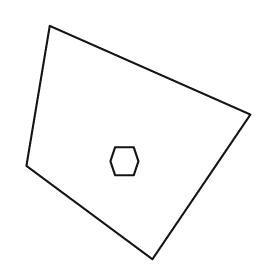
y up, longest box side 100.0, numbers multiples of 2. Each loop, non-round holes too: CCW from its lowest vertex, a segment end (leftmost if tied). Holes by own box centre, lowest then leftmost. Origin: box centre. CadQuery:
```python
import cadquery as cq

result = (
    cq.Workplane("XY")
    .moveTo(6.0, -50.0)
    .lineTo(48.0, 12.0)
    .lineTo(-38.0, 50.0)
    .lineTo(-48.0, -10.0)
    .close()
    .moveTo(-10.0, -14.0)
    .lineTo(-2.0, -14.0)
    .lineTo(0.0, -8.0)
    .lineTo(-2.0, -2.0)
    .lineTo(-10.0, -2.0)
    .lineTo(-12.0, -8.0)
    .close()
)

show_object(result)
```